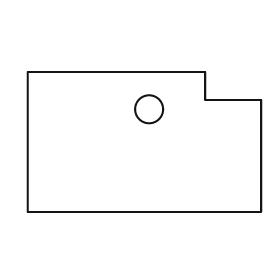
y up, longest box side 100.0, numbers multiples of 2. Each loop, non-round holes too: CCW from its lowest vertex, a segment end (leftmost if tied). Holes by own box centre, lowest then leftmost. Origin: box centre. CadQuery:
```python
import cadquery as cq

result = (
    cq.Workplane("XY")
    .moveTo(-50.0, -30.0)
    .lineTo(50.0, -30.0)
    .lineTo(50.0, 18.0)
    .lineTo(26.0, 18.0)
    .lineTo(26.0, 30.0)
    .lineTo(-50.0, 30.0)
    .close()
    .moveTo(2.0, 14.0)
    .circle(6.0)
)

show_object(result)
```